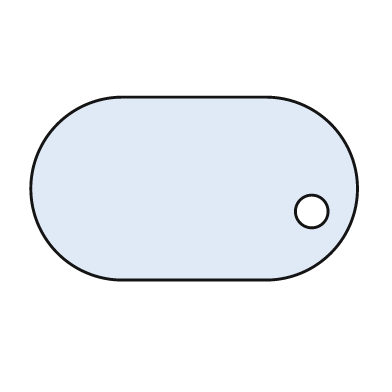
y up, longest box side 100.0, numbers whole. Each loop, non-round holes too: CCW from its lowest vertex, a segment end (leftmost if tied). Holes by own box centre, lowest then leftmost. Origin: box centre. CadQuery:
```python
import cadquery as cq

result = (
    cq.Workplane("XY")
    .moveTo(-22.0, -28.0)
    .lineTo(22.0, -28.0)
    .threePointArc((50.0, 0.0), (22.0, 28.0))
    .lineTo(-22.0, 28.0)
    .threePointArc((-50.0, 0.0), (-22.0, -28.0))
    .close()
    .moveTo(36.0, -7.0)
    .circle(5.0)
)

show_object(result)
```